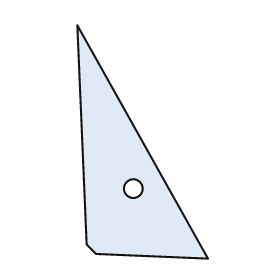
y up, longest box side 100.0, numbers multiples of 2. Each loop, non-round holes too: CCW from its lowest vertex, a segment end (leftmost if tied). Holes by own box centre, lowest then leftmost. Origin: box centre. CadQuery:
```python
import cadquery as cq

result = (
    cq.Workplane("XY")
    .moveTo(28.0, -50.0)
    .lineTo(-28.0, 50.0)
    .lineTo(-24.0, -44.0)
    .lineTo(-20.0, -48.0)
    .close()
    .moveTo(-4.0, -20.0)
    .circle(4.0)
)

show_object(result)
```